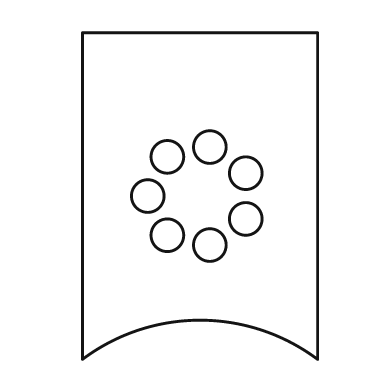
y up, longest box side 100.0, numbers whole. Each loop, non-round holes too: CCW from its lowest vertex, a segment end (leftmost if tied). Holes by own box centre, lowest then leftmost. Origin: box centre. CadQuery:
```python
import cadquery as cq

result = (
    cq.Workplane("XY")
    .moveTo(-36.0, -50.0)
    .threePointArc((0.0, -38.0), (36.0, -50.0))
    .lineTo(36.0, 50.0)
    .lineTo(-36.0, 50.0)
    .close()
    .moveTo(3.0, -15.0)
    .circle(5.0)
    .moveTo(-10.0, -12.0)
    .circle(5.0)
    .moveTo(14.0, -7.0)
    .circle(5.0)
    .moveTo(-16.0, 0.0)
    .circle(5.0)
    .moveTo(14.0, 7.0)
    .circle(5.0)
    .moveTo(-10.0, 12.0)
    .circle(5.0)
    .moveTo(3.0, 15.0)
    .circle(5.0)
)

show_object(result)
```